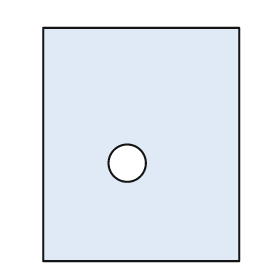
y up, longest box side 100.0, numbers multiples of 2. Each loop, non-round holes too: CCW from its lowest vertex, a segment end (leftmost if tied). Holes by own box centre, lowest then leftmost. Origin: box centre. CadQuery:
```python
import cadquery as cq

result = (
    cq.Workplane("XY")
    .moveTo(-42.0, -50.0)
    .lineTo(42.0, -50.0)
    .lineTo(42.0, 50.0)
    .lineTo(-42.0, 50.0)
    .close()
    .moveTo(-6.0, -8.0)
    .circle(8.0)
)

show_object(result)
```